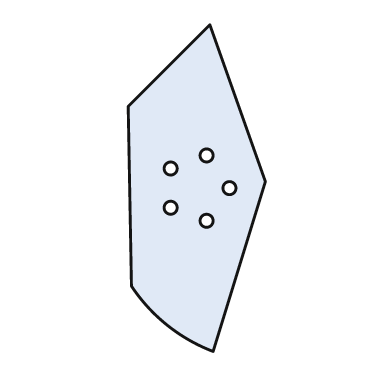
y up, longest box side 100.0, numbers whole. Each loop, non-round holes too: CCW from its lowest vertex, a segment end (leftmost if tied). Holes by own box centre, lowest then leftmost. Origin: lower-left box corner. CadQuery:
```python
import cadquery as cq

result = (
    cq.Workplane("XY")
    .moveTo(26.0, 0.0)
    .lineTo(42.0, 52.0)
    .lineTo(25.0, 100.0)
    .lineTo(0.0, 75.0)
    .lineTo(1.0, 20.0)
    .threePointArc((12.0, 8.0), (26.0, 0.0))
    .close()
    .moveTo(24.0, 40.0)
    .circle(2.0)
    .moveTo(13.0, 44.0)
    .circle(2.0)
    .moveTo(31.0, 50.0)
    .circle(2.0)
    .moveTo(13.0, 56.0)
    .circle(2.0)
    .moveTo(24.0, 60.0)
    .circle(2.0)
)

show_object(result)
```